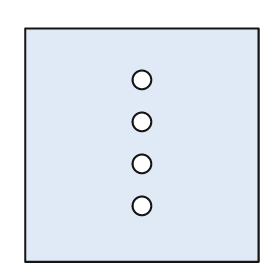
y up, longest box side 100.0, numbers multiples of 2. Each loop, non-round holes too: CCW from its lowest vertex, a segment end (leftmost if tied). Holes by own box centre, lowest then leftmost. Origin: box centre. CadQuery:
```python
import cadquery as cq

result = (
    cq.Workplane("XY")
    .moveTo(-50.0, -50.0)
    .lineTo(50.0, -50.0)
    .lineTo(50.0, 50.0)
    .lineTo(-50.0, 50.0)
    .close()
    .moveTo(0.0, -26.0)
    .circle(4.0)
    .moveTo(0.0, -8.0)
    .circle(4.0)
    .moveTo(0.0, 10.0)
    .circle(4.0)
    .moveTo(0.0, 28.0)
    .circle(4.0)
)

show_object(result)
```